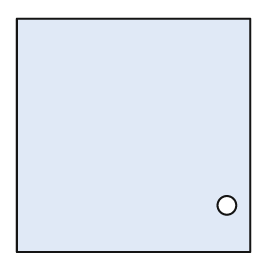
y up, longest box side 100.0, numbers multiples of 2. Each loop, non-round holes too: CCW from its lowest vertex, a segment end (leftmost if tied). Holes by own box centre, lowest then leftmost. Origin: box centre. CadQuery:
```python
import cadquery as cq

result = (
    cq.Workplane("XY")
    .moveTo(-50.0, -50.0)
    .lineTo(50.0, -50.0)
    .lineTo(50.0, 50.0)
    .lineTo(-50.0, 50.0)
    .close()
    .moveTo(40.0, -30.0)
    .circle(4.0)
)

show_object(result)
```